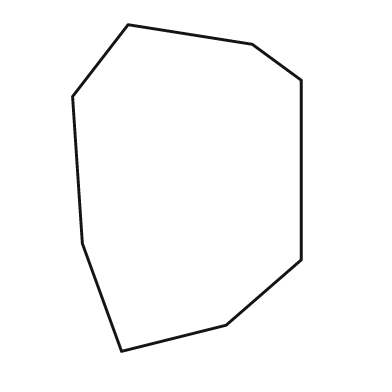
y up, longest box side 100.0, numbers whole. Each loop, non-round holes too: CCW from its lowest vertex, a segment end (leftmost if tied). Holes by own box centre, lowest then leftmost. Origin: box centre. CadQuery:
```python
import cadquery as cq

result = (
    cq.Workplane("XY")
    .moveTo(-20.0, -50.0)
    .lineTo(12.0, -42.0)
    .lineTo(35.0, -22.0)
    .lineTo(35.0, 33.0)
    .lineTo(20.0, 44.0)
    .lineTo(-18.0, 50.0)
    .lineTo(-35.0, 28.0)
    .lineTo(-32.0, -17.0)
    .close()
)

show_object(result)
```